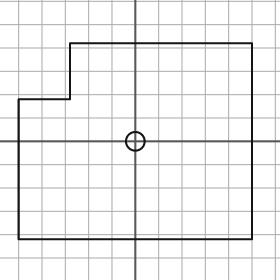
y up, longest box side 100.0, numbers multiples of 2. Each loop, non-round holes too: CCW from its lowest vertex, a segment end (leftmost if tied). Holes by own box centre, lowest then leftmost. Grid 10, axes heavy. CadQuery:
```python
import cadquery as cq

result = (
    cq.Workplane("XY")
    .moveTo(-50.0, -42.0)
    .lineTo(50.0, -42.0)
    .lineTo(50.0, 42.0)
    .lineTo(-28.0, 42.0)
    .lineTo(-28.0, 18.0)
    .lineTo(-50.0, 18.0)
    .close()
    .moveTo(0.0, 0.0)
    .circle(4.0)
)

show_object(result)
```